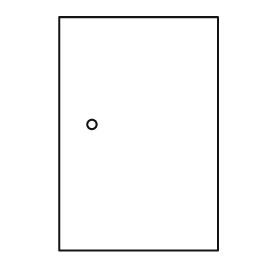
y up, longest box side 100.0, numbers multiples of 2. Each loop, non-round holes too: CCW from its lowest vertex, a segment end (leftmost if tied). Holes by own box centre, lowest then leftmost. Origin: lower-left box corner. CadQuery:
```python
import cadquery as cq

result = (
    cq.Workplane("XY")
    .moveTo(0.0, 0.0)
    .lineTo(68.0, 0.0)
    .lineTo(68.0, 100.0)
    .lineTo(0.0, 100.0)
    .close()
    .moveTo(14.0, 54.0)
    .circle(2.0)
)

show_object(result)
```